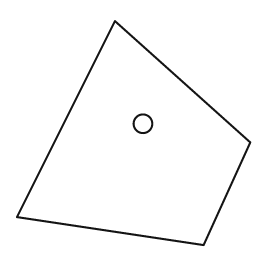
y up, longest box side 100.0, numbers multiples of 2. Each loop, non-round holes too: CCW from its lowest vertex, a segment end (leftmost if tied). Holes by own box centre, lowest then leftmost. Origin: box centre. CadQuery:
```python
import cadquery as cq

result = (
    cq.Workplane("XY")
    .moveTo(30.0, -48.0)
    .lineTo(50.0, -4.0)
    .lineTo(-8.0, 48.0)
    .lineTo(-50.0, -36.0)
    .close()
    .moveTo(4.0, 4.0)
    .circle(4.0)
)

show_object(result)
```